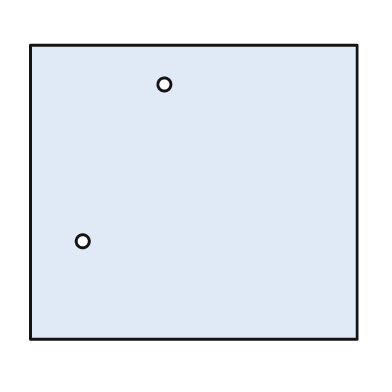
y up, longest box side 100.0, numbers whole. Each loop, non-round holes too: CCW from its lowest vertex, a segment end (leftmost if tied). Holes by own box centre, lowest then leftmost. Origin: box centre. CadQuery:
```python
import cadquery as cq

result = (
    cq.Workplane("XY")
    .moveTo(-50.0, -45.0)
    .lineTo(50.0, -45.0)
    .lineTo(50.0, 45.0)
    .lineTo(-50.0, 45.0)
    .close()
    .moveTo(-34.0, -15.0)
    .circle(2.0)
    .moveTo(-9.0, 33.0)
    .circle(2.0)
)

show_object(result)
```